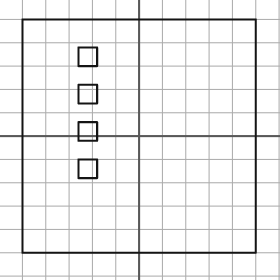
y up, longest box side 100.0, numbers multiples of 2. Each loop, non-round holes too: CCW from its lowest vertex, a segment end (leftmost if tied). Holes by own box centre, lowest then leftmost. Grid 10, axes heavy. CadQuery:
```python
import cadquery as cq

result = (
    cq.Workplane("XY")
    .moveTo(-50.0, -50.0)
    .lineTo(50.0, -50.0)
    .lineTo(50.0, 50.0)
    .lineTo(-50.0, 50.0)
    .close()
    .moveTo(-26.0, -18.0)
    .lineTo(-18.0, -18.0)
    .lineTo(-18.0, -10.0)
    .lineTo(-26.0, -10.0)
    .close()
    .moveTo(-26.0, -2.0)
    .lineTo(-18.0, -2.0)
    .lineTo(-18.0, 6.0)
    .lineTo(-26.0, 6.0)
    .close()
    .moveTo(-26.0, 14.0)
    .lineTo(-18.0, 14.0)
    .lineTo(-18.0, 22.0)
    .lineTo(-26.0, 22.0)
    .close()
    .moveTo(-26.0, 30.0)
    .lineTo(-18.0, 30.0)
    .lineTo(-18.0, 38.0)
    .lineTo(-26.0, 38.0)
    .close()
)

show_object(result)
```